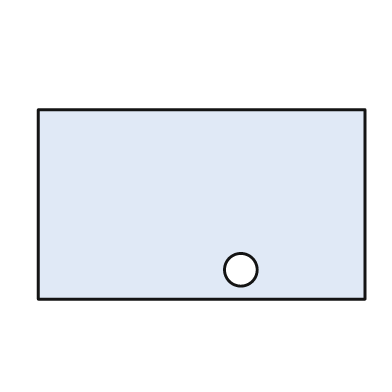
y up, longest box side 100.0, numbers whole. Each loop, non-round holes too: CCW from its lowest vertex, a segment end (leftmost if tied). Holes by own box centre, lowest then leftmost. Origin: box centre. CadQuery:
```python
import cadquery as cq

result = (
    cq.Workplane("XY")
    .moveTo(-50.0, -29.0)
    .lineTo(50.0, -29.0)
    .lineTo(50.0, 29.0)
    .lineTo(-50.0, 29.0)
    .close()
    .moveTo(12.0, -20.0)
    .circle(5.0)
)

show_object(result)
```